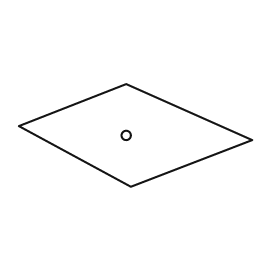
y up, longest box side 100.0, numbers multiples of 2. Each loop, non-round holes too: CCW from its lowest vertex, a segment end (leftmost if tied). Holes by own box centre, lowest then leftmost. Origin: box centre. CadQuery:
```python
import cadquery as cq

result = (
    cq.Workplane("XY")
    .moveTo(-2.0, -22.0)
    .lineTo(50.0, -2.0)
    .lineTo(-4.0, 22.0)
    .lineTo(-50.0, 4.0)
    .close()
    .moveTo(-4.0, 0.0)
    .circle(2.0)
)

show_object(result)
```